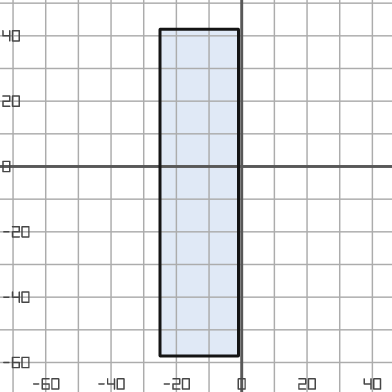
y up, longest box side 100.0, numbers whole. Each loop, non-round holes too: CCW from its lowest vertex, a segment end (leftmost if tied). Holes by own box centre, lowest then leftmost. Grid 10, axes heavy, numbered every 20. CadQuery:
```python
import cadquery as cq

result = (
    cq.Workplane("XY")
    .moveTo(-25.0, -58.0)
    .lineTo(-1.0, -58.0)
    .lineTo(-1.0, 42.0)
    .lineTo(-25.0, 42.0)
    .close()
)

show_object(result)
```